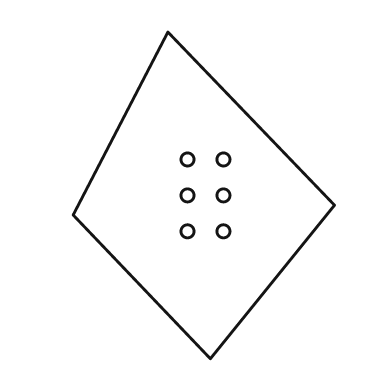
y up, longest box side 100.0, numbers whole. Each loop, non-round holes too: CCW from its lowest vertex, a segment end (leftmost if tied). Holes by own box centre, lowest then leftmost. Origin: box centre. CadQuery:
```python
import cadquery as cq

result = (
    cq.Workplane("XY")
    .moveTo(2.0, -50.0)
    .lineTo(40.0, -3.0)
    .lineTo(-11.0, 50.0)
    .lineTo(-40.0, -6.0)
    .close()
    .moveTo(-5.0, -11.0)
    .circle(2.0)
    .moveTo(6.0, -11.0)
    .circle(2.0)
    .moveTo(-5.0, 0.0)
    .circle(2.0)
    .moveTo(6.0, 0.0)
    .circle(2.0)
    .moveTo(-5.0, 11.0)
    .circle(2.0)
    .moveTo(6.0, 11.0)
    .circle(2.0)
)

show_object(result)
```